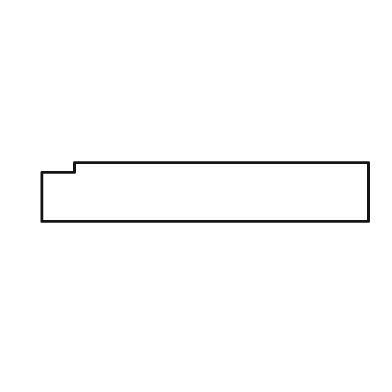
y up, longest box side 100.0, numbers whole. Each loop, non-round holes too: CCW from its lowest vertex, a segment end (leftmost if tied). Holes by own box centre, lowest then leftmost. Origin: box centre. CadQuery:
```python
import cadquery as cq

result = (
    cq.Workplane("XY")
    .moveTo(-50.0, -9.0)
    .lineTo(50.0, -9.0)
    .lineTo(50.0, 9.0)
    .lineTo(-40.0, 9.0)
    .lineTo(-40.0, 6.0)
    .lineTo(-50.0, 6.0)
    .close()
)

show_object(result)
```